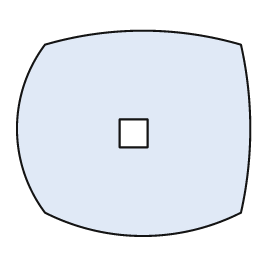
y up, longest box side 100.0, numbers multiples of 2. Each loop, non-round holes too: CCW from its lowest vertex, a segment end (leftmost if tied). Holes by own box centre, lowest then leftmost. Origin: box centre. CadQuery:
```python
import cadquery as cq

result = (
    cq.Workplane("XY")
    .moveTo(-38.0, -34.0)
    .threePointArc((4.0, -44.0), (46.0, -34.0))
    .threePointArc((50.0, 2.0), (46.0, 38.0))
    .threePointArc((4.0, 44.0), (-38.0, 38.0))
    .threePointArc((-50.0, 2.0), (-38.0, -34.0))
    .close()
    .moveTo(-6.0, -6.0)
    .lineTo(6.0, -6.0)
    .lineTo(6.0, 6.0)
    .lineTo(-6.0, 6.0)
    .close()
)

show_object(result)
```